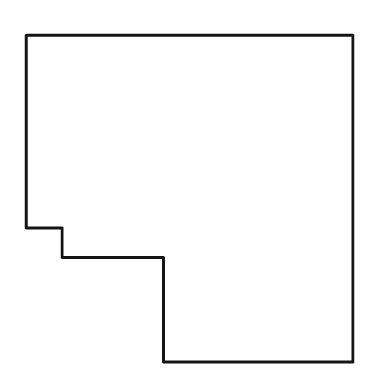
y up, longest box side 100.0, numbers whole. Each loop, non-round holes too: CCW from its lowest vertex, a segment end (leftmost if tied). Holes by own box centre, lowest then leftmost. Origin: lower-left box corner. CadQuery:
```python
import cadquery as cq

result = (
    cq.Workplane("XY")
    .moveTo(42.0, 0.0)
    .lineTo(100.0, 0.0)
    .lineTo(100.0, 100.0)
    .lineTo(0.0, 100.0)
    .lineTo(0.0, 41.0)
    .lineTo(11.0, 41.0)
    .lineTo(11.0, 32.0)
    .lineTo(42.0, 32.0)
    .close()
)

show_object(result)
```